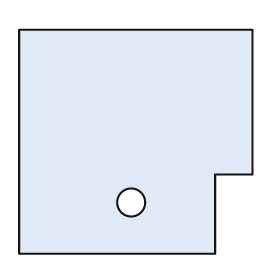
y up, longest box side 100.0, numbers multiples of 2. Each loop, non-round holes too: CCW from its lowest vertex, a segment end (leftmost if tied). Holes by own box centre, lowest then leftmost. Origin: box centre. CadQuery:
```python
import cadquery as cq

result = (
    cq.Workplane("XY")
    .moveTo(-50.0, -48.0)
    .lineTo(34.0, -48.0)
    .lineTo(34.0, -14.0)
    .lineTo(50.0, -14.0)
    .lineTo(50.0, 48.0)
    .lineTo(-50.0, 48.0)
    .close()
    .moveTo(-2.0, -26.0)
    .circle(6.0)
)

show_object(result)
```